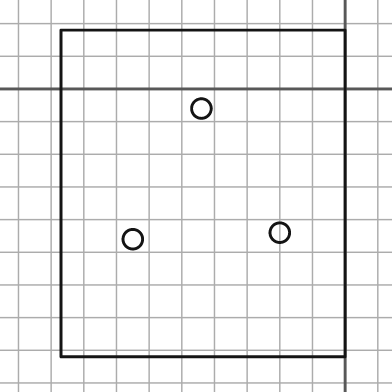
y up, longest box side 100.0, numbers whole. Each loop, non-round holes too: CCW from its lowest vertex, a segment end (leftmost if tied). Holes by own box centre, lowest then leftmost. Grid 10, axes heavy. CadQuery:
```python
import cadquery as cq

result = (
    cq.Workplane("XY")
    .moveTo(-87.0, -82.0)
    .lineTo(0.0, -82.0)
    .lineTo(0.0, 18.0)
    .lineTo(-87.0, 18.0)
    .close()
    .moveTo(-65.0, -46.0)
    .circle(3.0)
    .moveTo(-20.0, -44.0)
    .circle(3.0)
    .moveTo(-44.0, -6.0)
    .circle(3.0)
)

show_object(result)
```